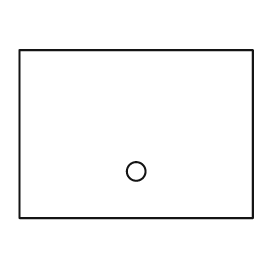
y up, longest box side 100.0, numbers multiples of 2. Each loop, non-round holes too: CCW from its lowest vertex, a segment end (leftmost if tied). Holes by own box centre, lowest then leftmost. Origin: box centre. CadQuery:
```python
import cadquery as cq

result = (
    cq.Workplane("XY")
    .moveTo(-50.0, -36.0)
    .lineTo(50.0, -36.0)
    .lineTo(50.0, 36.0)
    .lineTo(-50.0, 36.0)
    .close()
    .moveTo(0.0, -16.0)
    .circle(4.0)
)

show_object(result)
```